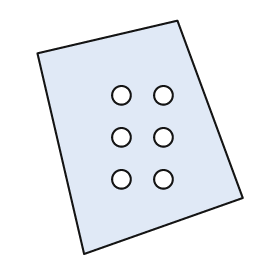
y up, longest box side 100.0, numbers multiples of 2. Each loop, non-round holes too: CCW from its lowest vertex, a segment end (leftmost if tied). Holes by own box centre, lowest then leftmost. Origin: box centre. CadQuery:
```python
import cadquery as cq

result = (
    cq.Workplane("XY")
    .moveTo(-24.0, -50.0)
    .lineTo(44.0, -26.0)
    .lineTo(16.0, 50.0)
    .lineTo(-44.0, 36.0)
    .close()
    .moveTo(-8.0, -18.0)
    .circle(4.0)
    .moveTo(10.0, -18.0)
    .circle(4.0)
    .moveTo(-8.0, 0.0)
    .circle(4.0)
    .moveTo(10.0, 0.0)
    .circle(4.0)
    .moveTo(-8.0, 18.0)
    .circle(4.0)
    .moveTo(10.0, 18.0)
    .circle(4.0)
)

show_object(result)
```